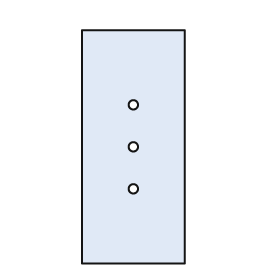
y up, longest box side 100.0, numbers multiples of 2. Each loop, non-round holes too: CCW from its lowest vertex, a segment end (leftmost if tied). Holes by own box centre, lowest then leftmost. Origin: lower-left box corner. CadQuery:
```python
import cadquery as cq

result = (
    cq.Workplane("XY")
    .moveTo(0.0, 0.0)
    .lineTo(44.0, 0.0)
    .lineTo(44.0, 100.0)
    .lineTo(0.0, 100.0)
    .close()
    .moveTo(22.0, 32.0)
    .circle(2.0)
    .moveTo(22.0, 50.0)
    .circle(2.0)
    .moveTo(22.0, 68.0)
    .circle(2.0)
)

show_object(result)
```